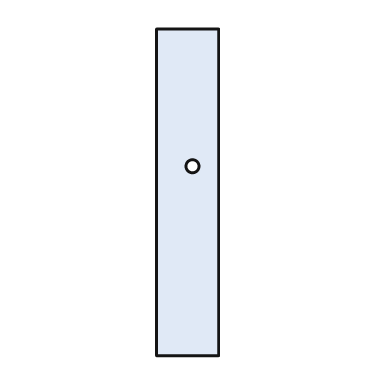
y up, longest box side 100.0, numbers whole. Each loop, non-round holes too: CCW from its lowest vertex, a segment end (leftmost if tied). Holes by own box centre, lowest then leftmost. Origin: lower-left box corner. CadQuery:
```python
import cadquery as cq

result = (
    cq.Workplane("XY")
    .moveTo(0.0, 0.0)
    .lineTo(19.0, 0.0)
    .lineTo(19.0, 100.0)
    .lineTo(0.0, 100.0)
    .close()
    .moveTo(11.0, 58.0)
    .circle(2.0)
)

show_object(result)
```